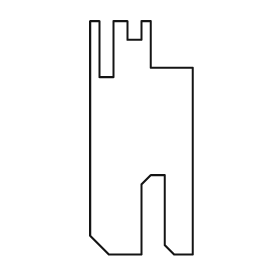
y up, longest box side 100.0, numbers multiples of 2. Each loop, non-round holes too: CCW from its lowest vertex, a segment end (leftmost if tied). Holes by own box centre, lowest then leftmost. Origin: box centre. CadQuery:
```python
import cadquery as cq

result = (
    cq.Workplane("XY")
    .moveTo(-14.0, -50.0)
    .lineTo(0.0, -50.0)
    .lineTo(0.0, -20.0)
    .lineTo(4.0, -16.0)
    .lineTo(10.0, -16.0)
    .lineTo(10.0, -46.0)
    .lineTo(14.0, -50.0)
    .lineTo(22.0, -50.0)
    .lineTo(22.0, 30.0)
    .lineTo(4.0, 30.0)
    .lineTo(4.0, 50.0)
    .lineTo(0.0, 50.0)
    .lineTo(0.0, 42.0)
    .lineTo(-6.0, 42.0)
    .lineTo(-6.0, 50.0)
    .lineTo(-12.0, 50.0)
    .lineTo(-12.0, 26.0)
    .lineTo(-18.0, 26.0)
    .lineTo(-18.0, 50.0)
    .lineTo(-22.0, 50.0)
    .lineTo(-22.0, -42.0)
    .close()
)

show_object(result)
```